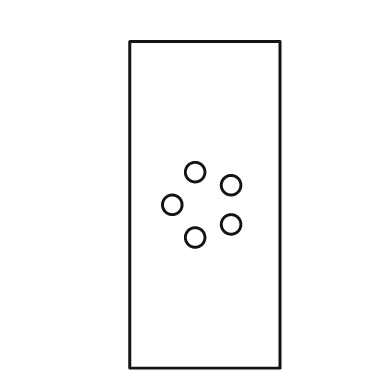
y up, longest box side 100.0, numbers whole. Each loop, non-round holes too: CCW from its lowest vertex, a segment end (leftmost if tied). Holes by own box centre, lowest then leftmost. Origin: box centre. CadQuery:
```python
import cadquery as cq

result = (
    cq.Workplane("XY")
    .moveTo(-23.0, -50.0)
    .lineTo(23.0, -50.0)
    .lineTo(23.0, 50.0)
    .lineTo(-23.0, 50.0)
    .close()
    .moveTo(-3.0, -10.0)
    .circle(3.0)
    .moveTo(8.0, -6.0)
    .circle(3.0)
    .moveTo(-10.0, 0.0)
    .circle(3.0)
    .moveTo(8.0, 6.0)
    .circle(3.0)
    .moveTo(-3.0, 10.0)
    .circle(3.0)
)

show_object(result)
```